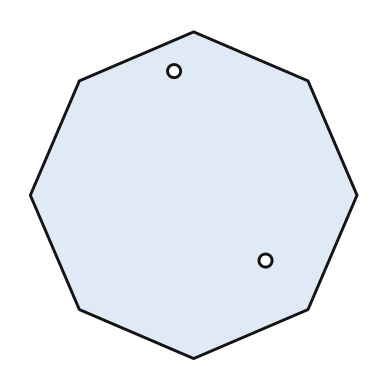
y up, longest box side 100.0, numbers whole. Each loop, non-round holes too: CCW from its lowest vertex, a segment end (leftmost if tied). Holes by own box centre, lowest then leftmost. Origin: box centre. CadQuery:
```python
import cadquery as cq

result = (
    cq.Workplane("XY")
    .moveTo(0.0, -50.0)
    .lineTo(35.0, -35.0)
    .lineTo(50.0, 0.0)
    .lineTo(35.0, 35.0)
    .lineTo(0.0, 50.0)
    .lineTo(-35.0, 35.0)
    .lineTo(-50.0, 0.0)
    .lineTo(-35.0, -35.0)
    .close()
    .moveTo(22.0, -20.0)
    .circle(2.0)
    .moveTo(-6.0, 38.0)
    .circle(2.0)
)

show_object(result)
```